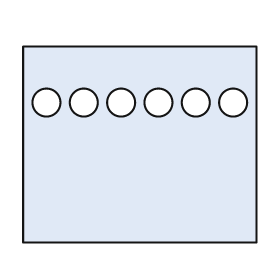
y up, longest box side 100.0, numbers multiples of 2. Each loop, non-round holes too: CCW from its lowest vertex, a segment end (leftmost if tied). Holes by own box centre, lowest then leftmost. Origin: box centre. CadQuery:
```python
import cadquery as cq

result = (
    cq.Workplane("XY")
    .moveTo(-50.0, -42.0)
    .lineTo(50.0, -42.0)
    .lineTo(50.0, 42.0)
    .lineTo(-50.0, 42.0)
    .close()
    .moveTo(-40.0, 18.0)
    .circle(6.0)
    .moveTo(-24.0, 18.0)
    .circle(6.0)
    .moveTo(-8.0, 18.0)
    .circle(6.0)
    .moveTo(8.0, 18.0)
    .circle(6.0)
    .moveTo(24.0, 18.0)
    .circle(6.0)
    .moveTo(40.0, 18.0)
    .circle(6.0)
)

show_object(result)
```